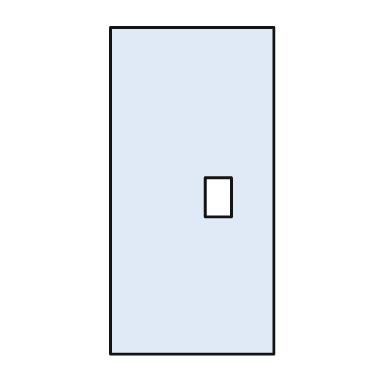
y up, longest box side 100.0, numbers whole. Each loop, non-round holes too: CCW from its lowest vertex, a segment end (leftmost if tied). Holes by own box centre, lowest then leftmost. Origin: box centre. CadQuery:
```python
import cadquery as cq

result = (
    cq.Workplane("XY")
    .moveTo(-25.0, -50.0)
    .lineTo(25.0, -50.0)
    .lineTo(25.0, 50.0)
    .lineTo(-25.0, 50.0)
    .close()
    .moveTo(4.0, -8.0)
    .lineTo(12.0, -8.0)
    .lineTo(12.0, 4.0)
    .lineTo(4.0, 4.0)
    .close()
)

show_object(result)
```